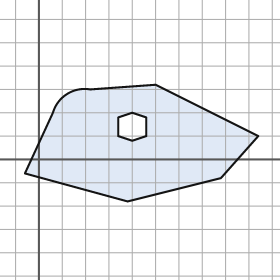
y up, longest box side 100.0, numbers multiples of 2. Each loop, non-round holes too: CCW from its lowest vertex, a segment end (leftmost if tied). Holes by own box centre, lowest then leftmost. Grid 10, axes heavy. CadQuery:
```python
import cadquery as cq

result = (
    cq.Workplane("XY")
    .moveTo(38.0, -18.0)
    .lineTo(78.0, -8.0)
    .lineTo(94.0, 10.0)
    .lineTo(50.0, 32.0)
    .lineTo(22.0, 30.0)
    .threePointArc((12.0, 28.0), (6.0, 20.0))
    .lineTo(-6.0, -6.0)
    .close()
    .moveTo(40.0, 8.0)
    .lineTo(46.0, 10.0)
    .lineTo(46.0, 18.0)
    .lineTo(40.0, 20.0)
    .lineTo(34.0, 18.0)
    .lineTo(34.0, 10.0)
    .close()
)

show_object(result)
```